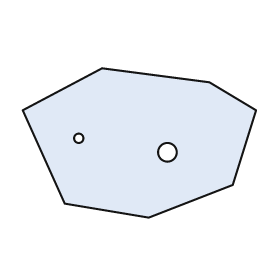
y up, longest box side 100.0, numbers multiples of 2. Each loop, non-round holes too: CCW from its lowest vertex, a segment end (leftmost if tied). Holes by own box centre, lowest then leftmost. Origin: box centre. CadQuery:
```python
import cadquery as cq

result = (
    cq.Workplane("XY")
    .moveTo(4.0, -32.0)
    .lineTo(40.0, -18.0)
    .lineTo(50.0, 14.0)
    .lineTo(30.0, 26.0)
    .lineTo(-16.0, 32.0)
    .lineTo(-50.0, 14.0)
    .lineTo(-32.0, -26.0)
    .close()
    .moveTo(12.0, -4.0)
    .circle(4.0)
    .moveTo(-26.0, 2.0)
    .circle(2.0)
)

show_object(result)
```